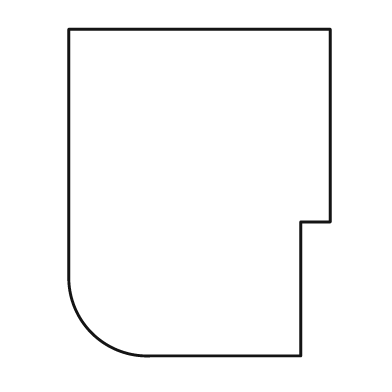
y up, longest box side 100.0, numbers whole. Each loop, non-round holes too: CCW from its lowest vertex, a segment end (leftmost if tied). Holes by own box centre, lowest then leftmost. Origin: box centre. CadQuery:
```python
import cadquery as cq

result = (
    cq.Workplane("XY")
    .moveTo(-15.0, -50.0)
    .lineTo(31.0, -50.0)
    .lineTo(31.0, -9.0)
    .lineTo(40.0, -9.0)
    .lineTo(40.0, 50.0)
    .lineTo(-40.0, 50.0)
    .lineTo(-40.0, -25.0)
    .threePointArc((-33.0, -43.0), (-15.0, -50.0))
    .close()
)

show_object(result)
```